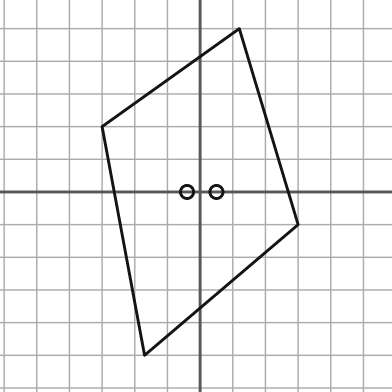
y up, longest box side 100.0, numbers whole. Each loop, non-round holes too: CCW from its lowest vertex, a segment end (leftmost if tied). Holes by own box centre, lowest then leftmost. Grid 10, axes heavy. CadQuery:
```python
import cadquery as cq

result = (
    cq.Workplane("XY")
    .moveTo(-17.0, -50.0)
    .lineTo(30.0, -10.0)
    .lineTo(12.0, 50.0)
    .lineTo(-30.0, 20.0)
    .close()
    .moveTo(-4.0, 0.0)
    .circle(2.0)
    .moveTo(5.0, 0.0)
    .circle(2.0)
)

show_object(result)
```